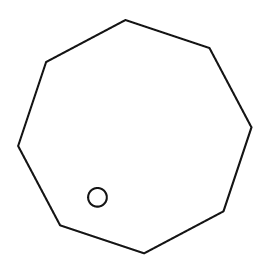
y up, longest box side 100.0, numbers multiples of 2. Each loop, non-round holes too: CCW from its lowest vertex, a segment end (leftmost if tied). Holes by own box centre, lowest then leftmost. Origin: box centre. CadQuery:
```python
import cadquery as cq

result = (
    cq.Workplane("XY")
    .moveTo(4.0, -50.0)
    .lineTo(38.0, -32.0)
    .lineTo(50.0, 4.0)
    .lineTo(32.0, 38.0)
    .lineTo(-4.0, 50.0)
    .lineTo(-38.0, 32.0)
    .lineTo(-50.0, -4.0)
    .lineTo(-32.0, -38.0)
    .close()
    .moveTo(-16.0, -26.0)
    .circle(4.0)
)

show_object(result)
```